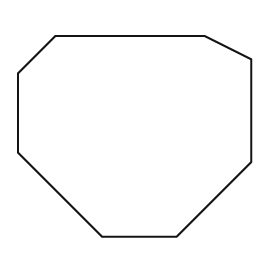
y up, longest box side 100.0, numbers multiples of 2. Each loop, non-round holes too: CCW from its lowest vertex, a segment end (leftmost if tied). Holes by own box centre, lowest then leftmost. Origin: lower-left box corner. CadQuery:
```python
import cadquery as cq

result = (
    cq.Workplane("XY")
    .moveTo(36.0, 0.0)
    .lineTo(68.0, 0.0)
    .lineTo(100.0, 32.0)
    .lineTo(100.0, 76.0)
    .lineTo(80.0, 86.0)
    .lineTo(16.0, 86.0)
    .lineTo(0.0, 70.0)
    .lineTo(0.0, 36.0)
    .close()
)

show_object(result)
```